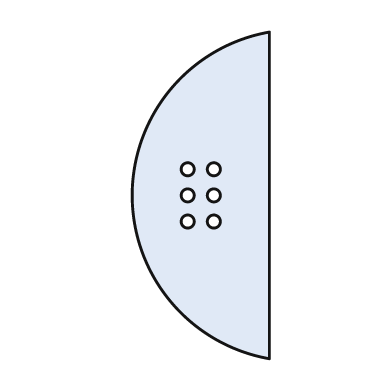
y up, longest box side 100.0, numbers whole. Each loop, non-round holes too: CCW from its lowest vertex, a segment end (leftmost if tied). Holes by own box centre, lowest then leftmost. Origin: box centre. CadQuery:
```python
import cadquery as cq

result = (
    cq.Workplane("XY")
    .moveTo(21.0, -50.0)
    .lineTo(21.0, 50.0)
    .threePointArc((-21.0, 0.0), (21.0, -50.0))
    .close()
    .moveTo(-4.0, -8.0)
    .circle(2.0)
    .moveTo(4.0, -8.0)
    .circle(2.0)
    .moveTo(-4.0, 0.0)
    .circle(2.0)
    .moveTo(4.0, 0.0)
    .circle(2.0)
    .moveTo(-4.0, 8.0)
    .circle(2.0)
    .moveTo(4.0, 8.0)
    .circle(2.0)
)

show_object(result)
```